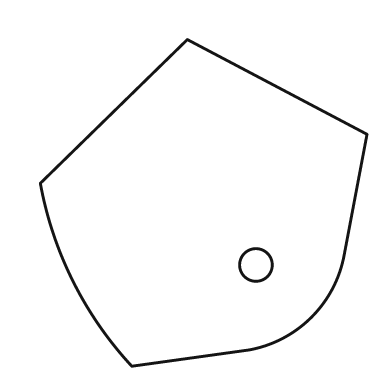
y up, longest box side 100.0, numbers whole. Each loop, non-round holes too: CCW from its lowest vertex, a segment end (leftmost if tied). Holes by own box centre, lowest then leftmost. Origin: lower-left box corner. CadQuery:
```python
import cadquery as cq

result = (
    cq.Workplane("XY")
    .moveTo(28.0, 0.0)
    .lineTo(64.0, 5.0)
    .threePointArc((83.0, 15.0), (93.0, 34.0))
    .lineTo(100.0, 71.0)
    .lineTo(45.0, 100.0)
    .lineTo(0.0, 56.0)
    .threePointArc((10.0, 26.0), (28.0, 0.0))
    .close()
    .moveTo(66.0, 31.0)
    .circle(5.0)
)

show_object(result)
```